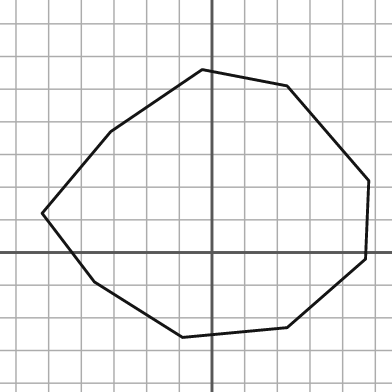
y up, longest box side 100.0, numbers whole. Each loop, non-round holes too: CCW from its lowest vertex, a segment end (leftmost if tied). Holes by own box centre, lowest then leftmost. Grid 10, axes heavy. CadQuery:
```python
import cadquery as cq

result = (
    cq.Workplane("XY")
    .moveTo(-9.0, -26.0)
    .lineTo(23.0, -23.0)
    .lineTo(47.0, -2.0)
    .lineTo(48.0, 22.0)
    .lineTo(23.0, 51.0)
    .lineTo(-3.0, 56.0)
    .lineTo(-31.0, 37.0)
    .lineTo(-52.0, 12.0)
    .lineTo(-36.0, -9.0)
    .close()
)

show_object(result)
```